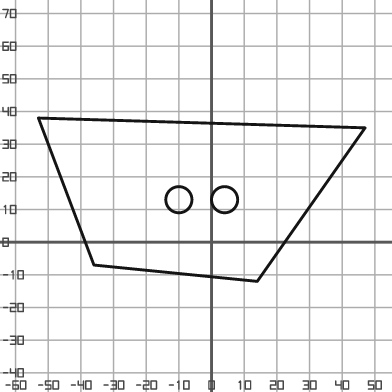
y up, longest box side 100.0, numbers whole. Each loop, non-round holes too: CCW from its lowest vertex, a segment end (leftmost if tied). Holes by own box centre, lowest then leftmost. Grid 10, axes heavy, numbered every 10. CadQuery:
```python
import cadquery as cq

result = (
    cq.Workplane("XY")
    .moveTo(14.0, -12.0)
    .lineTo(47.0, 35.0)
    .lineTo(-53.0, 38.0)
    .lineTo(-36.0, -7.0)
    .close()
    .moveTo(-10.0, 13.0)
    .circle(4.0)
    .moveTo(4.0, 13.0)
    .circle(4.0)
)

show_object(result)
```